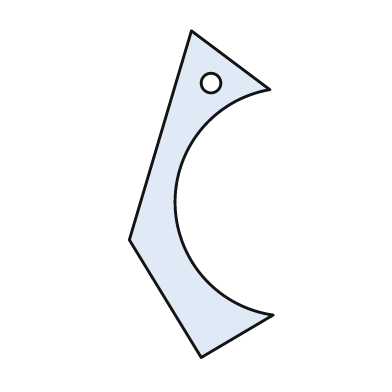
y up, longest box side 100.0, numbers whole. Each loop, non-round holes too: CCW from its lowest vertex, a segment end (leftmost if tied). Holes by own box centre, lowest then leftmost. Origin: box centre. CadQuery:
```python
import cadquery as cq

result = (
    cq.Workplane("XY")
    .moveTo(0.0, -50.0)
    .lineTo(22.0, -37.0)
    .threePointArc((-8.0, -3.0), (21.0, 32.0))
    .lineTo(-3.0, 50.0)
    .lineTo(-22.0, -14.0)
    .close()
    .moveTo(3.0, 34.0)
    .circle(3.0)
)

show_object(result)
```